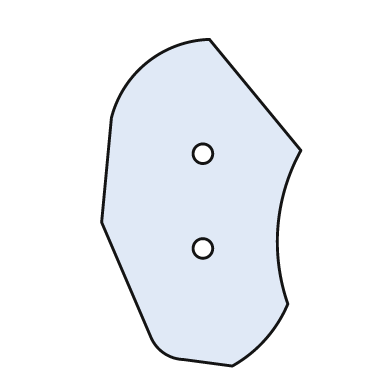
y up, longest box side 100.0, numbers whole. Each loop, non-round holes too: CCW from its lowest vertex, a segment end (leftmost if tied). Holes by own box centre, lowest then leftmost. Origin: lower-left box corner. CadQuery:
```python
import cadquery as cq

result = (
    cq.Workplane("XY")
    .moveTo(40.0, 0.0)
    .threePointArc((50.0, 8.0), (57.0, 19.0))
    .threePointArc((54.0, 43.0), (61.0, 66.0))
    .lineTo(33.0, 100.0)
    .threePointArc((14.0, 93.0), (3.0, 76.0))
    .lineTo(0.0, 44.0)
    .lineTo(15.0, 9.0)
    .threePointArc((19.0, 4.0), (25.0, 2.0))
    .close()
    .moveTo(31.0, 36.0)
    .circle(3.0)
    .moveTo(31.0, 65.0)
    .circle(3.0)
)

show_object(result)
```